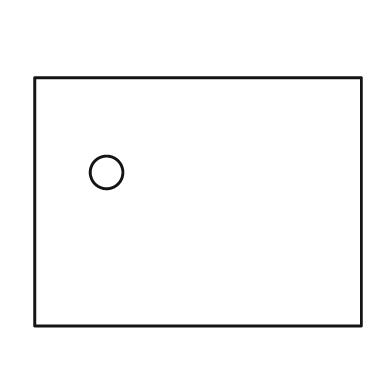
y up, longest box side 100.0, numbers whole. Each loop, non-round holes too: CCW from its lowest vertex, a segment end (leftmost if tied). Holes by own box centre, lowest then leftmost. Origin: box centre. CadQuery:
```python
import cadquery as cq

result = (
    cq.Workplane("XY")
    .moveTo(-50.0, -38.0)
    .lineTo(50.0, -38.0)
    .lineTo(50.0, 38.0)
    .lineTo(-50.0, 38.0)
    .close()
    .moveTo(-28.0, 9.0)
    .circle(5.0)
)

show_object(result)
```